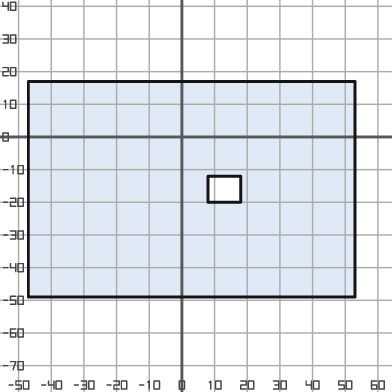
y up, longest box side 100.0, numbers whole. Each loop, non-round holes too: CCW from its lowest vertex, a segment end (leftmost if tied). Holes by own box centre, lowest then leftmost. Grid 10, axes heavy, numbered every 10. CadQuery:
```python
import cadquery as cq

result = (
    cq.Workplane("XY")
    .moveTo(-47.0, -49.0)
    .lineTo(53.0, -49.0)
    .lineTo(53.0, 17.0)
    .lineTo(-47.0, 17.0)
    .close()
    .moveTo(8.0, -20.0)
    .lineTo(18.0, -20.0)
    .lineTo(18.0, -12.0)
    .lineTo(8.0, -12.0)
    .close()
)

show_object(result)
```